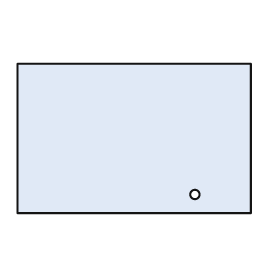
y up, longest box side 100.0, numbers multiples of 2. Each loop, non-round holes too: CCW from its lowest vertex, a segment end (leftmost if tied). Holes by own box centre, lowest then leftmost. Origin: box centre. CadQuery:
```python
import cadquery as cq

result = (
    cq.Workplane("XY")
    .moveTo(-50.0, -32.0)
    .lineTo(50.0, -32.0)
    .lineTo(50.0, 32.0)
    .lineTo(-50.0, 32.0)
    .close()
    .moveTo(26.0, -24.0)
    .circle(2.0)
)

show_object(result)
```